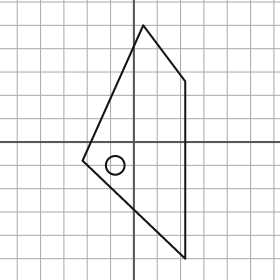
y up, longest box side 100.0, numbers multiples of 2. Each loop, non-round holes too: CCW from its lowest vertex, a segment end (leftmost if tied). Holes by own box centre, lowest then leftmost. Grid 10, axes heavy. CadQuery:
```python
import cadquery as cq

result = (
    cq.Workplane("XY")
    .moveTo(22.0, -50.0)
    .lineTo(22.0, 26.0)
    .lineTo(4.0, 50.0)
    .lineTo(-22.0, -8.0)
    .close()
    .moveTo(-8.0, -10.0)
    .circle(4.0)
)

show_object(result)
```